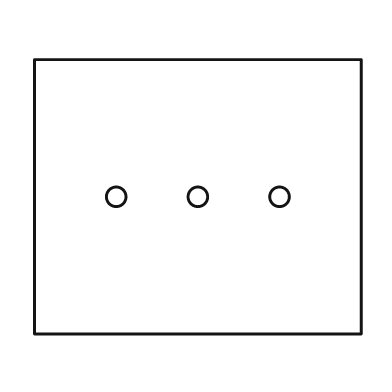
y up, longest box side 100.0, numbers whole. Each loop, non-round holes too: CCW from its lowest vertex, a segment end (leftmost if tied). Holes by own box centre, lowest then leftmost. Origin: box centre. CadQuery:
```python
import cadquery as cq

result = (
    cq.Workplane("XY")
    .moveTo(-50.0, -42.0)
    .lineTo(50.0, -42.0)
    .lineTo(50.0, 42.0)
    .lineTo(-50.0, 42.0)
    .close()
    .moveTo(-25.0, 0.0)
    .circle(3.0)
    .moveTo(0.0, 0.0)
    .circle(3.0)
    .moveTo(25.0, 0.0)
    .circle(3.0)
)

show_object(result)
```